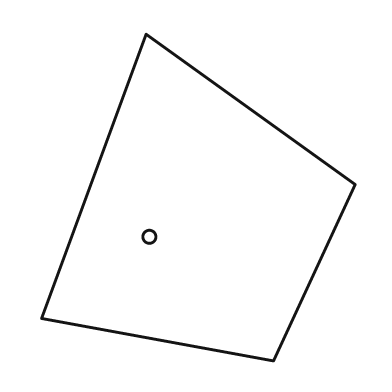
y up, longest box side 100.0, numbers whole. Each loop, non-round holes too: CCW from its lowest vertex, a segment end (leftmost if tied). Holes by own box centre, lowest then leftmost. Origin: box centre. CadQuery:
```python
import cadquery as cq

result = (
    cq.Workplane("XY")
    .moveTo(23.0, -50.0)
    .lineTo(48.0, 4.0)
    .lineTo(-16.0, 50.0)
    .lineTo(-48.0, -37.0)
    .close()
    .moveTo(-15.0, -12.0)
    .circle(2.0)
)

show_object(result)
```